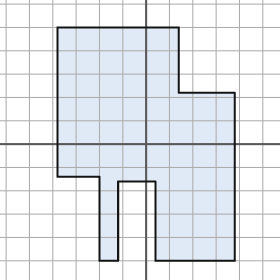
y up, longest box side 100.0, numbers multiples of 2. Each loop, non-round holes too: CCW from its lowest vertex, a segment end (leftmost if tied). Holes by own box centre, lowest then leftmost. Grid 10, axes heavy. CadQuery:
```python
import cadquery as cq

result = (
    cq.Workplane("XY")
    .moveTo(-20.0, -50.0)
    .lineTo(-12.0, -50.0)
    .lineTo(-12.0, -16.0)
    .lineTo(4.0, -16.0)
    .lineTo(4.0, -50.0)
    .lineTo(38.0, -50.0)
    .lineTo(38.0, 22.0)
    .lineTo(14.0, 22.0)
    .lineTo(14.0, 50.0)
    .lineTo(-38.0, 50.0)
    .lineTo(-38.0, -14.0)
    .lineTo(-20.0, -14.0)
    .close()
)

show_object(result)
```